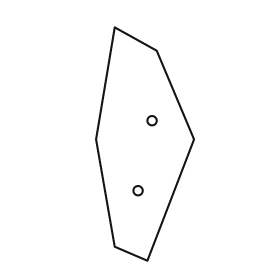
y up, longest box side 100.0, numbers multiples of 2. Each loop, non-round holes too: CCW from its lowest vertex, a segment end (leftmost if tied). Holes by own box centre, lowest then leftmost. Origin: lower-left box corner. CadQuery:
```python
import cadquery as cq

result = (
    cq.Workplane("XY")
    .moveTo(22.0, 0.0)
    .lineTo(42.0, 52.0)
    .lineTo(26.0, 90.0)
    .lineTo(8.0, 100.0)
    .lineTo(0.0, 52.0)
    .lineTo(8.0, 6.0)
    .close()
    .moveTo(18.0, 30.0)
    .circle(2.0)
    .moveTo(24.0, 60.0)
    .circle(2.0)
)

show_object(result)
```